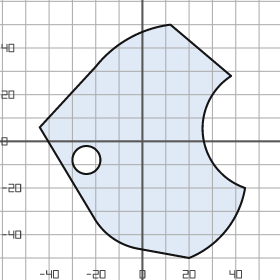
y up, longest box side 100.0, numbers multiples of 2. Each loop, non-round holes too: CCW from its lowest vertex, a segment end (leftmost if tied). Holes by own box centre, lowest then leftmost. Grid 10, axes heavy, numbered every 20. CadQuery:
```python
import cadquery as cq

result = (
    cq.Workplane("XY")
    .moveTo(20.0, -50.0)
    .threePointArc((36.0, -38.0), (44.0, -20.0))
    .threePointArc((26.0, 2.0), (38.0, 28.0))
    .lineTo(12.0, 50.0)
    .threePointArc((-6.0, 44.0), (-20.0, 32.0))
    .lineTo(-44.0, 6.0)
    .lineTo(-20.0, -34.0)
    .threePointArc((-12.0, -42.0), (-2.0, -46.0))
    .close()
    .moveTo(-24.0, -8.0)
    .circle(6.0)
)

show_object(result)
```